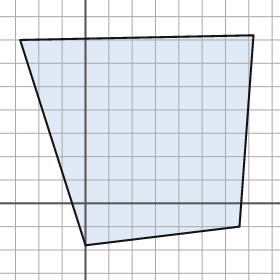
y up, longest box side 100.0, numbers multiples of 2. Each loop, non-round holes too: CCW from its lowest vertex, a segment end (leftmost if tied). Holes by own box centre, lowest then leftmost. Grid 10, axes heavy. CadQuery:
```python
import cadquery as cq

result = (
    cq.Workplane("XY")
    .moveTo(0.0, -18.0)
    .lineTo(66.0, -10.0)
    .lineTo(72.0, 72.0)
    .lineTo(-28.0, 70.0)
    .close()
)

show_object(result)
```